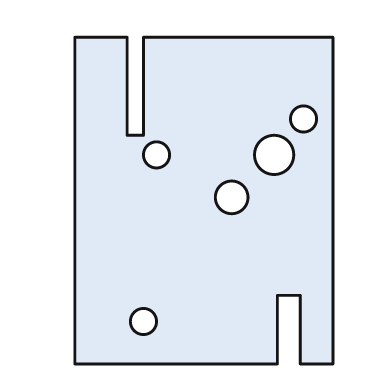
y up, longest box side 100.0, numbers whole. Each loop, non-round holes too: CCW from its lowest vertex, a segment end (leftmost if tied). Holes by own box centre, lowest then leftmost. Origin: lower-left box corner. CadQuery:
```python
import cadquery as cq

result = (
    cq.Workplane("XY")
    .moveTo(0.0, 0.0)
    .lineTo(62.0, 0.0)
    .lineTo(62.0, 21.0)
    .lineTo(69.0, 21.0)
    .lineTo(69.0, 0.0)
    .lineTo(79.0, 0.0)
    .lineTo(79.0, 100.0)
    .lineTo(21.0, 100.0)
    .lineTo(21.0, 70.0)
    .lineTo(16.0, 70.0)
    .lineTo(16.0, 100.0)
    .lineTo(0.0, 100.0)
    .close()
    .moveTo(21.0, 13.0)
    .circle(4.0)
    .moveTo(48.0, 51.0)
    .circle(5.0)
    .moveTo(25.0, 64.0)
    .circle(4.0)
    .moveTo(61.0, 64.0)
    .circle(6.0)
    .moveTo(70.0, 75.0)
    .circle(4.0)
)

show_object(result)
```